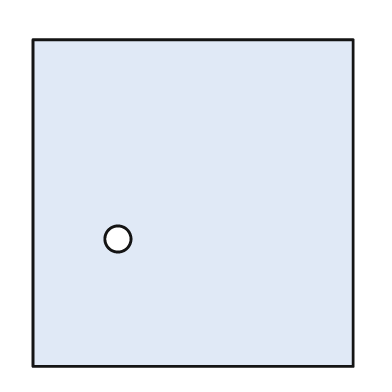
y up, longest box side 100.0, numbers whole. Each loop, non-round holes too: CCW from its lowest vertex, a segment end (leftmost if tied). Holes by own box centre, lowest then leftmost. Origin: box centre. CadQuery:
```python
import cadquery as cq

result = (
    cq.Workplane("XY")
    .moveTo(-49.0, -50.0)
    .lineTo(49.0, -50.0)
    .lineTo(49.0, 50.0)
    .lineTo(-49.0, 50.0)
    .close()
    .moveTo(-23.0, -11.0)
    .circle(4.0)
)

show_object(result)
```